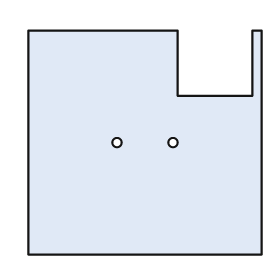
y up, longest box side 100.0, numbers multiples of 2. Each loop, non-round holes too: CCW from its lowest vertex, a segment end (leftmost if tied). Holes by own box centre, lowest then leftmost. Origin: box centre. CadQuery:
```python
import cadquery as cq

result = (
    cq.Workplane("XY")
    .moveTo(-50.0, -48.0)
    .lineTo(50.0, -48.0)
    .lineTo(50.0, 48.0)
    .lineTo(46.0, 48.0)
    .lineTo(46.0, 20.0)
    .lineTo(14.0, 20.0)
    .lineTo(14.0, 48.0)
    .lineTo(-50.0, 48.0)
    .close()
    .moveTo(-12.0, 0.0)
    .circle(2.0)
    .moveTo(12.0, 0.0)
    .circle(2.0)
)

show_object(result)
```